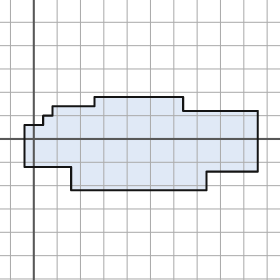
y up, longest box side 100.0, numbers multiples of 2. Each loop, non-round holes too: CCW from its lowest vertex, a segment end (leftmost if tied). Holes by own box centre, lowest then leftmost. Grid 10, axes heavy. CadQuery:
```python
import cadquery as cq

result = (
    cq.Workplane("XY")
    .moveTo(16.0, -22.0)
    .lineTo(74.0, -22.0)
    .lineTo(74.0, -14.0)
    .lineTo(96.0, -14.0)
    .lineTo(96.0, 12.0)
    .lineTo(64.0, 12.0)
    .lineTo(64.0, 18.0)
    .lineTo(26.0, 18.0)
    .lineTo(26.0, 14.0)
    .lineTo(8.0, 14.0)
    .lineTo(8.0, 10.0)
    .lineTo(4.0, 10.0)
    .lineTo(4.0, 6.0)
    .lineTo(-4.0, 6.0)
    .lineTo(-4.0, -12.0)
    .lineTo(16.0, -12.0)
    .close()
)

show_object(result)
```